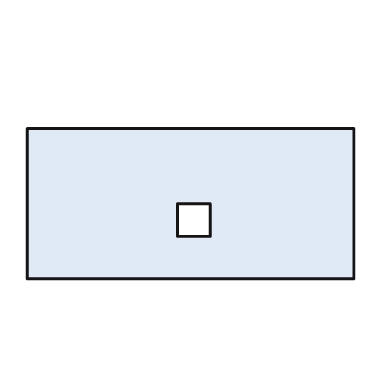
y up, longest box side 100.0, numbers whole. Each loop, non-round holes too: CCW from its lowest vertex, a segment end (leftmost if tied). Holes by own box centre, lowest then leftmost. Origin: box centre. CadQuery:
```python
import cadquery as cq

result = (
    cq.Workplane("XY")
    .moveTo(-50.0, -23.0)
    .lineTo(50.0, -23.0)
    .lineTo(50.0, 23.0)
    .lineTo(-50.0, 23.0)
    .close()
    .moveTo(-4.0, -10.0)
    .lineTo(6.0, -10.0)
    .lineTo(6.0, 0.0)
    .lineTo(-4.0, 0.0)
    .close()
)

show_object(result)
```